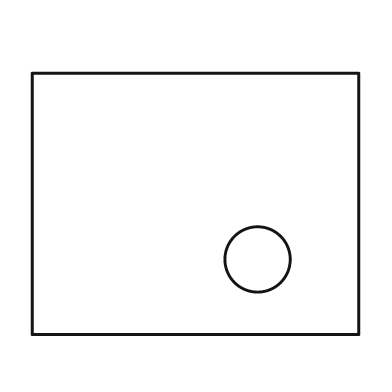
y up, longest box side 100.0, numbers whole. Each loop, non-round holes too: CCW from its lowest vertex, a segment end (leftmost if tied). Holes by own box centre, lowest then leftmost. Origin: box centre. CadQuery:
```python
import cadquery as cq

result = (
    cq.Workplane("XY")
    .moveTo(-50.0, -40.0)
    .lineTo(50.0, -40.0)
    .lineTo(50.0, 40.0)
    .lineTo(-50.0, 40.0)
    .close()
    .moveTo(19.0, -17.0)
    .circle(10.0)
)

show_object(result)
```